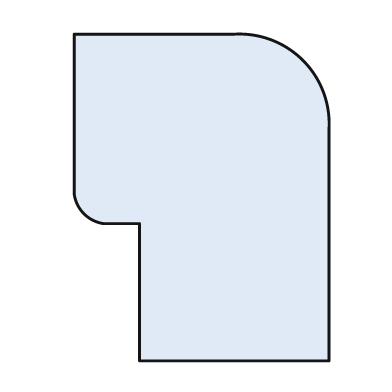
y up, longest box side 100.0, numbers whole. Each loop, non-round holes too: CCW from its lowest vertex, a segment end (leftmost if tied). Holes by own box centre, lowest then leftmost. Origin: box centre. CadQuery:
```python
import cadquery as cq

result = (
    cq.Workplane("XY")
    .moveTo(-19.0, -50.0)
    .lineTo(39.0, -50.0)
    .lineTo(39.0, 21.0)
    .threePointArc((31.0, 42.0), (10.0, 50.0))
    .lineTo(-39.0, 50.0)
    .lineTo(-39.0, 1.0)
    .threePointArc((-36.0, -5.0), (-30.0, -8.0))
    .lineTo(-19.0, -8.0)
    .close()
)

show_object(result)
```